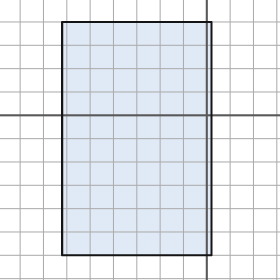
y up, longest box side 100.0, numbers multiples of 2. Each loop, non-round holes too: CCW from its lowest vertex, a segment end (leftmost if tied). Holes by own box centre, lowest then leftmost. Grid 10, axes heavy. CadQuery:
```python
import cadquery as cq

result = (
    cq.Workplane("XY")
    .moveTo(-62.0, -60.0)
    .lineTo(2.0, -60.0)
    .lineTo(2.0, 40.0)
    .lineTo(-62.0, 40.0)
    .close()
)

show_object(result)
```